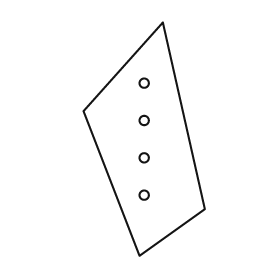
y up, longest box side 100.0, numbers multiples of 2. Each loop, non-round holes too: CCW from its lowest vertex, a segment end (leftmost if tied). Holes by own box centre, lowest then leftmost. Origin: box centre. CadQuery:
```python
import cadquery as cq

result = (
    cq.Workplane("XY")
    .moveTo(-2.0, -50.0)
    .lineTo(26.0, -30.0)
    .lineTo(8.0, 50.0)
    .lineTo(-26.0, 12.0)
    .close()
    .moveTo(0.0, -24.0)
    .circle(2.0)
    .moveTo(0.0, -8.0)
    .circle(2.0)
    .moveTo(0.0, 8.0)
    .circle(2.0)
    .moveTo(0.0, 24.0)
    .circle(2.0)
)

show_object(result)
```